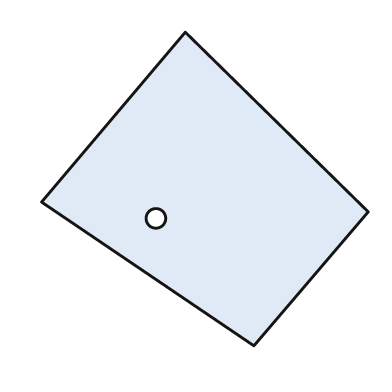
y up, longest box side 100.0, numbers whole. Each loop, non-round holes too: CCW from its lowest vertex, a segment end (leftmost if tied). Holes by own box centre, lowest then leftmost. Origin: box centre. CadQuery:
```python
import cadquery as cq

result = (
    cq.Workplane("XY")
    .moveTo(15.0, -48.0)
    .lineTo(50.0, -7.0)
    .lineTo(-6.0, 48.0)
    .lineTo(-50.0, -4.0)
    .close()
    .moveTo(-15.0, -9.0)
    .circle(3.0)
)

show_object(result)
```